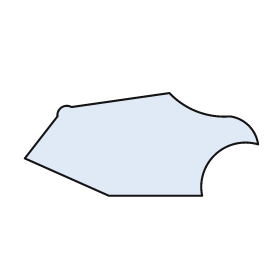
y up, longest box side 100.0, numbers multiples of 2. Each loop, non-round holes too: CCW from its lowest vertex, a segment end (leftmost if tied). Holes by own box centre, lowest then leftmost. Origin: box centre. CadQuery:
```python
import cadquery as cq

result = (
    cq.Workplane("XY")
    .moveTo(-14.0, -22.0)
    .lineTo(26.0, -22.0)
    .threePointArc((32.0, -4.0), (50.0, 0.0))
    .threePointArc((46.0, 8.0), (38.0, 12.0))
    .threePointArc((24.0, 14.0), (12.0, 22.0))
    .lineTo(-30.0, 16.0)
    .threePointArc((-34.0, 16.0), (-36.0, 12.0))
    .lineTo(-50.0, -6.0)
    .close()
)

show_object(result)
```